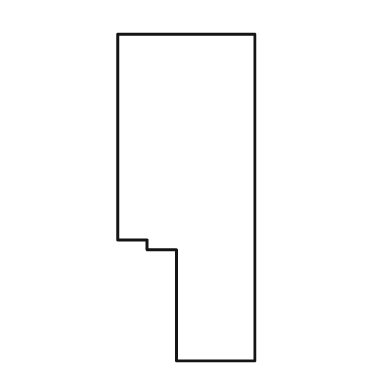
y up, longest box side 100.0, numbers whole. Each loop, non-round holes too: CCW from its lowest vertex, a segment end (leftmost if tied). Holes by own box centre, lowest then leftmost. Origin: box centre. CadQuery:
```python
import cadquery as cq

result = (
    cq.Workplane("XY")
    .moveTo(-3.0, -50.0)
    .lineTo(21.0, -50.0)
    .lineTo(21.0, 50.0)
    .lineTo(-21.0, 50.0)
    .lineTo(-21.0, -13.0)
    .lineTo(-12.0, -13.0)
    .lineTo(-12.0, -16.0)
    .lineTo(-3.0, -16.0)
    .close()
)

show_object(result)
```